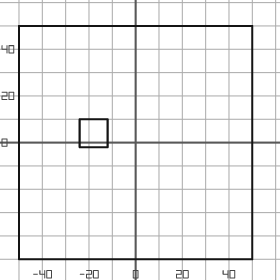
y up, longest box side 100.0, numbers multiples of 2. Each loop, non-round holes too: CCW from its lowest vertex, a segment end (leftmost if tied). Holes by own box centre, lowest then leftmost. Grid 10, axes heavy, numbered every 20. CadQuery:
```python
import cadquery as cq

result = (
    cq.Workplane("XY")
    .moveTo(-50.0, -50.0)
    .lineTo(50.0, -50.0)
    .lineTo(50.0, 50.0)
    .lineTo(-50.0, 50.0)
    .close()
    .moveTo(-24.0, -2.0)
    .lineTo(-12.0, -2.0)
    .lineTo(-12.0, 10.0)
    .lineTo(-24.0, 10.0)
    .close()
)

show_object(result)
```